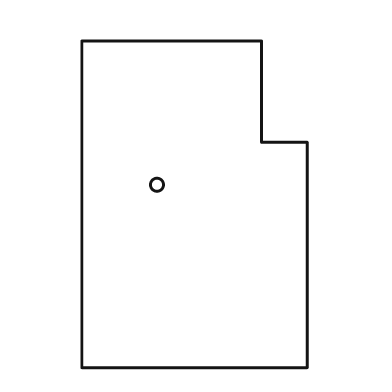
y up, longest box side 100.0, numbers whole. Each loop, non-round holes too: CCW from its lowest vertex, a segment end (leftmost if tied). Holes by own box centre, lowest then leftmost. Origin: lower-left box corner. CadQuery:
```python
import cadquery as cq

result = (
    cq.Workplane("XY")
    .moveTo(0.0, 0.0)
    .lineTo(69.0, 0.0)
    .lineTo(69.0, 69.0)
    .lineTo(55.0, 69.0)
    .lineTo(55.0, 100.0)
    .lineTo(0.0, 100.0)
    .close()
    .moveTo(23.0, 56.0)
    .circle(2.0)
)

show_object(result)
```